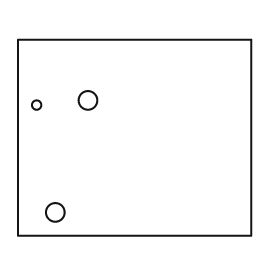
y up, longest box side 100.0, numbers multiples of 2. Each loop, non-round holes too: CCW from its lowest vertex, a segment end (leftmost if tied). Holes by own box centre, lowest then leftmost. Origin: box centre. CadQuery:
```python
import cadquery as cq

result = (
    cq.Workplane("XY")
    .moveTo(-50.0, -42.0)
    .lineTo(50.0, -42.0)
    .lineTo(50.0, 42.0)
    .lineTo(-50.0, 42.0)
    .close()
    .moveTo(-34.0, -32.0)
    .circle(4.0)
    .moveTo(-42.0, 14.0)
    .circle(2.0)
    .moveTo(-20.0, 16.0)
    .circle(4.0)
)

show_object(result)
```